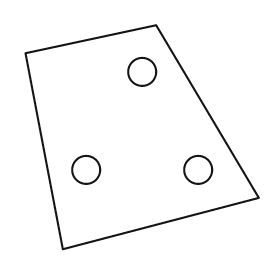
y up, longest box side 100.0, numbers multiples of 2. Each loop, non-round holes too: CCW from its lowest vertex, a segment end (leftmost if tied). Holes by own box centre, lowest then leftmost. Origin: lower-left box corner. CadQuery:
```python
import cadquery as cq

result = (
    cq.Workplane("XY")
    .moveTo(16.0, 0.0)
    .lineTo(100.0, 22.0)
    .lineTo(56.0, 96.0)
    .lineTo(0.0, 84.0)
    .close()
    .moveTo(26.0, 34.0)
    .circle(6.0)
    .moveTo(74.0, 34.0)
    .circle(6.0)
    .moveTo(50.0, 76.0)
    .circle(6.0)
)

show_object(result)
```